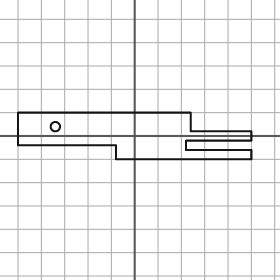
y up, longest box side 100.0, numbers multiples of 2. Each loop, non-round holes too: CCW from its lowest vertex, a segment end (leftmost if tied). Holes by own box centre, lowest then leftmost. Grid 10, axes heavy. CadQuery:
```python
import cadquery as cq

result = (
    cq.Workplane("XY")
    .moveTo(-8.0, -10.0)
    .lineTo(50.0, -10.0)
    .lineTo(50.0, -6.0)
    .lineTo(22.0, -6.0)
    .lineTo(22.0, -2.0)
    .lineTo(50.0, -2.0)
    .lineTo(50.0, 2.0)
    .lineTo(24.0, 2.0)
    .lineTo(24.0, 10.0)
    .lineTo(-50.0, 10.0)
    .lineTo(-50.0, -4.0)
    .lineTo(-8.0, -4.0)
    .close()
    .moveTo(-34.0, 4.0)
    .circle(2.0)
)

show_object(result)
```